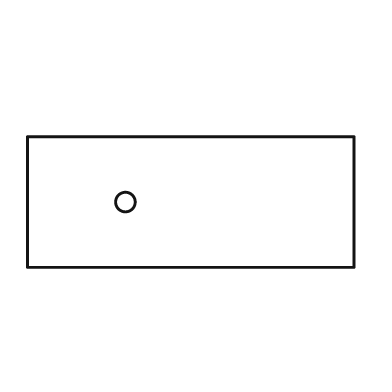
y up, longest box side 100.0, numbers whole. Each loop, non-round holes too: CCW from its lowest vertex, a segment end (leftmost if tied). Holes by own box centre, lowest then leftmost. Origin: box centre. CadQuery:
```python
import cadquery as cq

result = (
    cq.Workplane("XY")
    .moveTo(-50.0, -20.0)
    .lineTo(50.0, -20.0)
    .lineTo(50.0, 20.0)
    .lineTo(-50.0, 20.0)
    .close()
    .moveTo(-20.0, 0.0)
    .circle(3.0)
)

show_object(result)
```